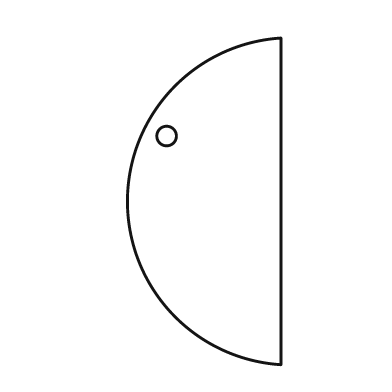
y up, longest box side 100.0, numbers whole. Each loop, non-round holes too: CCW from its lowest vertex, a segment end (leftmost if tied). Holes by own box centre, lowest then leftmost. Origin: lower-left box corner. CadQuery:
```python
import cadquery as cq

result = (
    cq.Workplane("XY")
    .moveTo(47.0, 0.0)
    .lineTo(47.0, 100.0)
    .threePointArc((0.0, 50.0), (47.0, 0.0))
    .close()
    .moveTo(12.0, 70.0)
    .circle(3.0)
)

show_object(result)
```